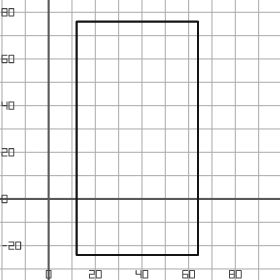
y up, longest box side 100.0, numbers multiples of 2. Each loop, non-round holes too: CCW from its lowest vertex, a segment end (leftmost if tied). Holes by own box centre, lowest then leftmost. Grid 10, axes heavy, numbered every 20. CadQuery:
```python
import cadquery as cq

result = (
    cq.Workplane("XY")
    .moveTo(12.0, -24.0)
    .lineTo(64.0, -24.0)
    .lineTo(64.0, 76.0)
    .lineTo(12.0, 76.0)
    .close()
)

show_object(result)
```